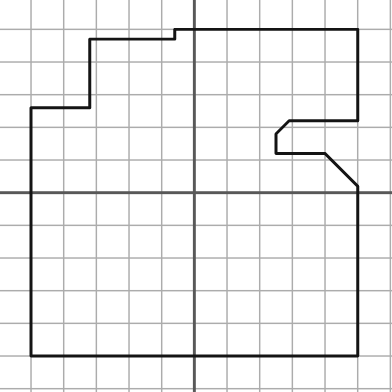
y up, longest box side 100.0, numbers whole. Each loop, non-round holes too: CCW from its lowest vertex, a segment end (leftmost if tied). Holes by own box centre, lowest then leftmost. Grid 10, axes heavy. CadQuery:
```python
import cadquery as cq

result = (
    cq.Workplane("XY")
    .moveTo(-50.0, -50.0)
    .lineTo(50.0, -50.0)
    .lineTo(50.0, 2.0)
    .lineTo(40.0, 12.0)
    .lineTo(25.0, 12.0)
    .lineTo(25.0, 18.0)
    .lineTo(29.0, 22.0)
    .lineTo(50.0, 22.0)
    .lineTo(50.0, 50.0)
    .lineTo(-6.0, 50.0)
    .lineTo(-6.0, 47.0)
    .lineTo(-32.0, 47.0)
    .lineTo(-32.0, 26.0)
    .lineTo(-50.0, 26.0)
    .close()
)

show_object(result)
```